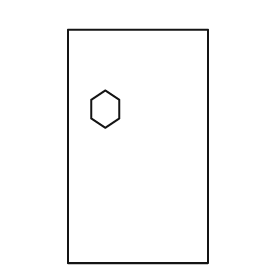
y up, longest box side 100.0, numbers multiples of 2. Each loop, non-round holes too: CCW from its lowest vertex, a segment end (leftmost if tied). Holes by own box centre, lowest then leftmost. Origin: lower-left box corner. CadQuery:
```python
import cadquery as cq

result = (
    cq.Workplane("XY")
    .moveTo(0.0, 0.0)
    .lineTo(60.0, 0.0)
    .lineTo(60.0, 100.0)
    .lineTo(0.0, 100.0)
    .close()
    .moveTo(16.0, 58.0)
    .lineTo(22.0, 62.0)
    .lineTo(22.0, 70.0)
    .lineTo(16.0, 74.0)
    .lineTo(10.0, 70.0)
    .lineTo(10.0, 62.0)
    .close()
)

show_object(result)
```